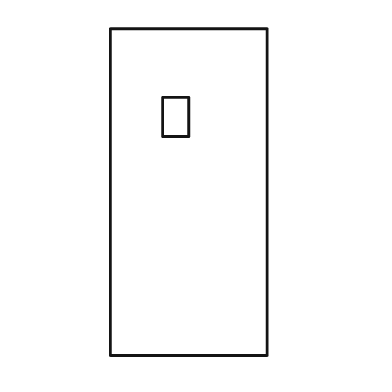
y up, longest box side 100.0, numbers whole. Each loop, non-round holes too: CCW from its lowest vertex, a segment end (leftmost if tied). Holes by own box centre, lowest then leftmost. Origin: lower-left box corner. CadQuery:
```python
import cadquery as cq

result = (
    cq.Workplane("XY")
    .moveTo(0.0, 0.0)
    .lineTo(48.0, 0.0)
    .lineTo(48.0, 100.0)
    .lineTo(0.0, 100.0)
    .close()
    .moveTo(16.0, 67.0)
    .lineTo(24.0, 67.0)
    .lineTo(24.0, 79.0)
    .lineTo(16.0, 79.0)
    .close()
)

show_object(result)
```